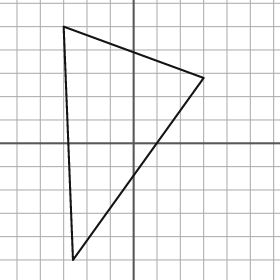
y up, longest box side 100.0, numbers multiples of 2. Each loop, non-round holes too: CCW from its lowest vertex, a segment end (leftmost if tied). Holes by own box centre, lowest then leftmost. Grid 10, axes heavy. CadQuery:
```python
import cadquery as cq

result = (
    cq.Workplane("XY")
    .moveTo(-26.0, -50.0)
    .lineTo(30.0, 28.0)
    .lineTo(-30.0, 50.0)
    .close()
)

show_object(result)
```